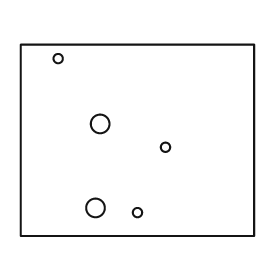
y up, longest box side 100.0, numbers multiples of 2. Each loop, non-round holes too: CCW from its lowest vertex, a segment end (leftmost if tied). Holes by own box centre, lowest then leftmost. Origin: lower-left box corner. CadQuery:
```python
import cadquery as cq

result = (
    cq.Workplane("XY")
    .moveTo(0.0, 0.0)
    .lineTo(100.0, 0.0)
    .lineTo(100.0, 82.0)
    .lineTo(0.0, 82.0)
    .close()
    .moveTo(50.0, 10.0)
    .circle(2.0)
    .moveTo(32.0, 12.0)
    .circle(4.0)
    .moveTo(62.0, 38.0)
    .circle(2.0)
    .moveTo(34.0, 48.0)
    .circle(4.0)
    .moveTo(16.0, 76.0)
    .circle(2.0)
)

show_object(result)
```